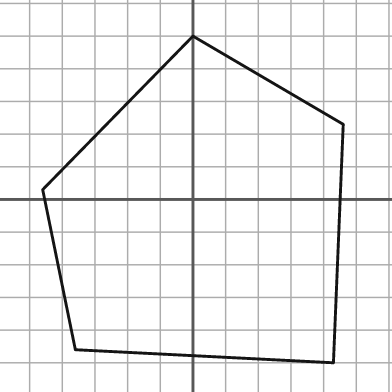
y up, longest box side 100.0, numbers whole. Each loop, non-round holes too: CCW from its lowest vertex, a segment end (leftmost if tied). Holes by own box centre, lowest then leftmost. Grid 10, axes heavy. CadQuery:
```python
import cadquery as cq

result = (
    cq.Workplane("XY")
    .moveTo(43.0, -50.0)
    .lineTo(46.0, 23.0)
    .lineTo(0.0, 50.0)
    .lineTo(-46.0, 3.0)
    .lineTo(-36.0, -46.0)
    .close()
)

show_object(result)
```